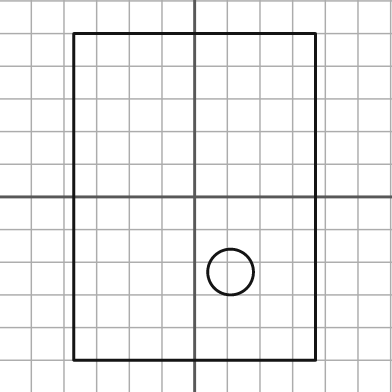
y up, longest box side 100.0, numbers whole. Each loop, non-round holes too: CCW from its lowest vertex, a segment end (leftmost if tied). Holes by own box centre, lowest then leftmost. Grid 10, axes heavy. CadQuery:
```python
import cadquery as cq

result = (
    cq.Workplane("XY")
    .moveTo(-37.0, -50.0)
    .lineTo(37.0, -50.0)
    .lineTo(37.0, 50.0)
    .lineTo(-37.0, 50.0)
    .close()
    .moveTo(11.0, -23.0)
    .circle(7.0)
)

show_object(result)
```